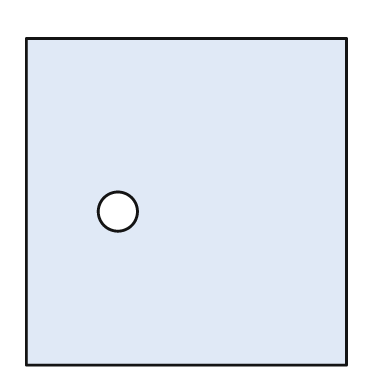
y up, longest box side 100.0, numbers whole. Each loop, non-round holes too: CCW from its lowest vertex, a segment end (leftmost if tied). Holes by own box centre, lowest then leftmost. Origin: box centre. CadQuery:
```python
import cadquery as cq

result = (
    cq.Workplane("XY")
    .moveTo(-49.0, -50.0)
    .lineTo(49.0, -50.0)
    .lineTo(49.0, 50.0)
    .lineTo(-49.0, 50.0)
    .close()
    .moveTo(-21.0, -3.0)
    .circle(6.0)
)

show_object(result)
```